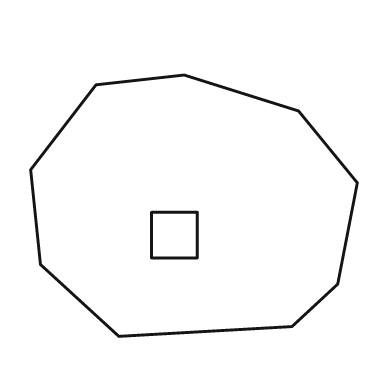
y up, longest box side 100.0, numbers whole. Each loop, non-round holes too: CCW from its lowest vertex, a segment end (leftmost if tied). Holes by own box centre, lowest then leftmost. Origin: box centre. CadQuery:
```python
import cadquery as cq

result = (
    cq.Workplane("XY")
    .moveTo(-23.0, -40.0)
    .lineTo(30.0, -37.0)
    .lineTo(44.0, -24.0)
    .lineTo(50.0, 7.0)
    .lineTo(32.0, 29.0)
    .lineTo(-3.0, 40.0)
    .lineTo(-30.0, 37.0)
    .lineTo(-50.0, 11.0)
    .lineTo(-47.0, -18.0)
    .close()
    .moveTo(-13.0, -16.0)
    .lineTo(1.0, -16.0)
    .lineTo(1.0, -2.0)
    .lineTo(-13.0, -2.0)
    .close()
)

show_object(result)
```